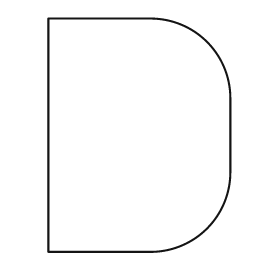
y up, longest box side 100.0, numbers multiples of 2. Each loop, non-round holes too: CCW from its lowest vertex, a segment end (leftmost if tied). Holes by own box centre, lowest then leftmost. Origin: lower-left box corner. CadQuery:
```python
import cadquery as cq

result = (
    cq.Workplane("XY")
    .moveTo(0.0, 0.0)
    .lineTo(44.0, 0.0)
    .threePointArc((68.0, 10.0), (78.0, 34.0))
    .lineTo(78.0, 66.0)
    .threePointArc((68.0, 90.0), (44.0, 100.0))
    .lineTo(0.0, 100.0)
    .close()
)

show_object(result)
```